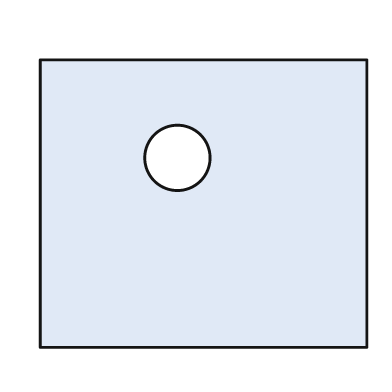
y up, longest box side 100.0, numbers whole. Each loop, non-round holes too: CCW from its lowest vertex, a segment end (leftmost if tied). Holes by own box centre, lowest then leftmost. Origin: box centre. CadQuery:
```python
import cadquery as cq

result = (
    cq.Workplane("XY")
    .moveTo(-50.0, -44.0)
    .lineTo(50.0, -44.0)
    .lineTo(50.0, 44.0)
    .lineTo(-50.0, 44.0)
    .close()
    .moveTo(-8.0, 14.0)
    .circle(10.0)
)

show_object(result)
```